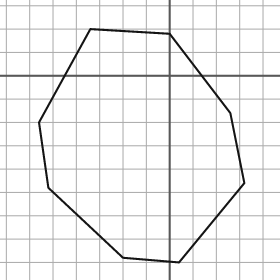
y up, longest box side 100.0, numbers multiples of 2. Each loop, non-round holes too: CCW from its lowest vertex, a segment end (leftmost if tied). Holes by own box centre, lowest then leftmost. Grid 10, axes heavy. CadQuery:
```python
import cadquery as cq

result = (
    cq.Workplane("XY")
    .moveTo(4.0, -80.0)
    .lineTo(32.0, -46.0)
    .lineTo(26.0, -16.0)
    .lineTo(0.0, 18.0)
    .lineTo(-34.0, 20.0)
    .lineTo(-56.0, -20.0)
    .lineTo(-52.0, -48.0)
    .lineTo(-20.0, -78.0)
    .close()
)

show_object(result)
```